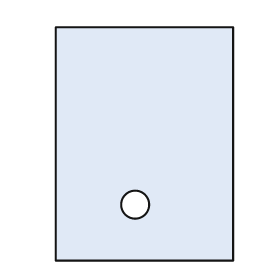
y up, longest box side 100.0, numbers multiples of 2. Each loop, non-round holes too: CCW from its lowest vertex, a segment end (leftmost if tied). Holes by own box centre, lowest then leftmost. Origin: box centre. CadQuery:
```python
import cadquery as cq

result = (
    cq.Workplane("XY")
    .moveTo(-38.0, -50.0)
    .lineTo(38.0, -50.0)
    .lineTo(38.0, 50.0)
    .lineTo(-38.0, 50.0)
    .close()
    .moveTo(-4.0, -26.0)
    .circle(6.0)
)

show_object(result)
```